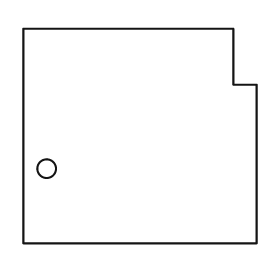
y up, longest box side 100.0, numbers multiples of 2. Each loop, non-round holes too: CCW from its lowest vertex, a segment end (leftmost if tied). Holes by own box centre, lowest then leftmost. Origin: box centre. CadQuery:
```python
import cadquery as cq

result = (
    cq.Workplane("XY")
    .moveTo(-50.0, -46.0)
    .lineTo(50.0, -46.0)
    .lineTo(50.0, 22.0)
    .lineTo(40.0, 22.0)
    .lineTo(40.0, 46.0)
    .lineTo(-50.0, 46.0)
    .close()
    .moveTo(-40.0, -14.0)
    .circle(4.0)
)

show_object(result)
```